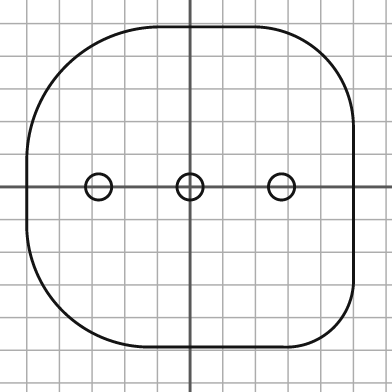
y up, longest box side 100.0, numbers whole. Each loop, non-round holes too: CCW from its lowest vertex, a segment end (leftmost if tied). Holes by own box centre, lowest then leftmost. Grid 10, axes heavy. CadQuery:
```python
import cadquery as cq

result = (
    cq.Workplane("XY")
    .moveTo(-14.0, -49.0)
    .lineTo(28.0, -49.0)
    .threePointArc((44.0, -43.0), (50.0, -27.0))
    .lineTo(50.0, 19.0)
    .threePointArc((41.0, 40.0), (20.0, 49.0))
    .lineTo(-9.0, 49.0)
    .threePointArc((-38.0, 37.0), (-50.0, 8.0))
    .lineTo(-50.0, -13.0)
    .threePointArc((-39.0, -38.0), (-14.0, -49.0))
    .close()
    .moveTo(-28.0, 0.0)
    .circle(4.0)
    .moveTo(0.0, 0.0)
    .circle(4.0)
    .moveTo(28.0, 0.0)
    .circle(4.0)
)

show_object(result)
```